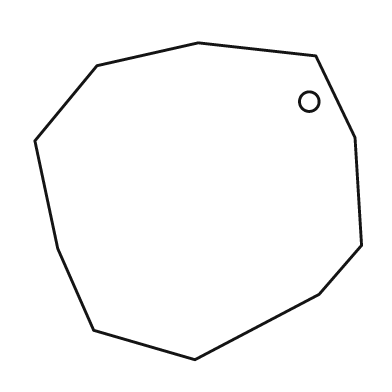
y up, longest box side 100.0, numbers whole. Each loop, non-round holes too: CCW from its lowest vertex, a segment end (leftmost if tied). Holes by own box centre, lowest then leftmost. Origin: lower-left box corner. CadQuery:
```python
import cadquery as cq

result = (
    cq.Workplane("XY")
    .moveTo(49.0, 0.0)
    .lineTo(87.0, 20.0)
    .lineTo(100.0, 35.0)
    .lineTo(98.0, 68.0)
    .lineTo(86.0, 93.0)
    .lineTo(50.0, 97.0)
    .lineTo(19.0, 90.0)
    .lineTo(0.0, 67.0)
    .lineTo(7.0, 34.0)
    .lineTo(18.0, 9.0)
    .close()
    .moveTo(84.0, 79.0)
    .circle(3.0)
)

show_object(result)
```